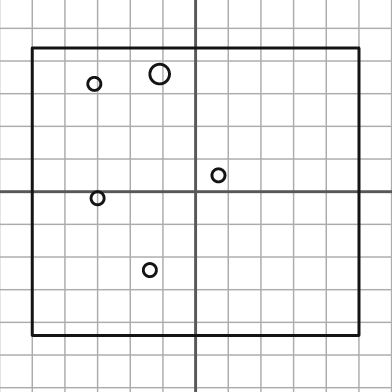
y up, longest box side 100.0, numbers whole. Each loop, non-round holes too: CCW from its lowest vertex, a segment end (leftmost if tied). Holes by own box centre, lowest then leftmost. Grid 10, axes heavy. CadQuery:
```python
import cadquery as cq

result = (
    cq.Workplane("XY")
    .moveTo(-50.0, -44.0)
    .lineTo(50.0, -44.0)
    .lineTo(50.0, 44.0)
    .lineTo(-50.0, 44.0)
    .close()
    .moveTo(-14.0, -24.0)
    .circle(2.0)
    .moveTo(-30.0, -2.0)
    .circle(2.0)
    .moveTo(7.0, 5.0)
    .circle(2.0)
    .moveTo(-31.0, 33.0)
    .circle(2.0)
    .moveTo(-11.0, 36.0)
    .circle(3.0)
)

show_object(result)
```